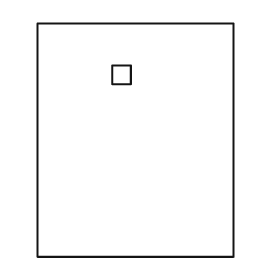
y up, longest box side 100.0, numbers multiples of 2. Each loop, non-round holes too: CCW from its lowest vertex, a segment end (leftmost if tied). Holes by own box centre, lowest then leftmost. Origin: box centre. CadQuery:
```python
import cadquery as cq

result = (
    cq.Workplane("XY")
    .moveTo(-42.0, -50.0)
    .lineTo(42.0, -50.0)
    .lineTo(42.0, 50.0)
    .lineTo(-42.0, 50.0)
    .close()
    .moveTo(-10.0, 24.0)
    .lineTo(-2.0, 24.0)
    .lineTo(-2.0, 32.0)
    .lineTo(-10.0, 32.0)
    .close()
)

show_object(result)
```